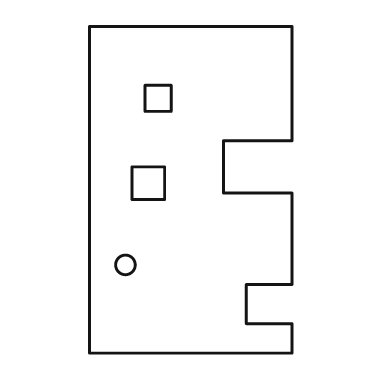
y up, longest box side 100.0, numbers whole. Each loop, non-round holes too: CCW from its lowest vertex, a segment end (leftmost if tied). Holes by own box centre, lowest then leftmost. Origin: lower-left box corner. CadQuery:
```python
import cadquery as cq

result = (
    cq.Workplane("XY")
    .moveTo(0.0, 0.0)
    .lineTo(62.0, 0.0)
    .lineTo(62.0, 9.0)
    .lineTo(48.0, 9.0)
    .lineTo(48.0, 21.0)
    .lineTo(62.0, 21.0)
    .lineTo(62.0, 49.0)
    .lineTo(41.0, 49.0)
    .lineTo(41.0, 65.0)
    .lineTo(62.0, 65.0)
    .lineTo(62.0, 100.0)
    .lineTo(0.0, 100.0)
    .close()
    .moveTo(11.0, 27.0)
    .circle(3.0)
    .moveTo(13.0, 47.0)
    .lineTo(23.0, 47.0)
    .lineTo(23.0, 57.0)
    .lineTo(13.0, 57.0)
    .close()
    .moveTo(17.0, 74.0)
    .lineTo(25.0, 74.0)
    .lineTo(25.0, 82.0)
    .lineTo(17.0, 82.0)
    .close()
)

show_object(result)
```